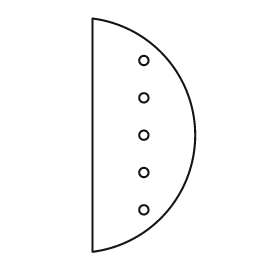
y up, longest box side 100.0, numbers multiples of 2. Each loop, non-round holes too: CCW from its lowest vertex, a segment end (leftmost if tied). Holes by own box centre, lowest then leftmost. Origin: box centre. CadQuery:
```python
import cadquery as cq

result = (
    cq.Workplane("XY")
    .moveTo(-22.0, -50.0)
    .threePointArc((22.0, 0.0), (-22.0, 50.0))
    .close()
    .moveTo(0.0, -32.0)
    .circle(2.0)
    .moveTo(0.0, -16.0)
    .circle(2.0)
    .moveTo(0.0, 0.0)
    .circle(2.0)
    .moveTo(0.0, 16.0)
    .circle(2.0)
    .moveTo(0.0, 32.0)
    .circle(2.0)
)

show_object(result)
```